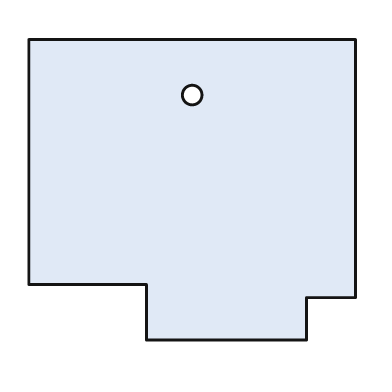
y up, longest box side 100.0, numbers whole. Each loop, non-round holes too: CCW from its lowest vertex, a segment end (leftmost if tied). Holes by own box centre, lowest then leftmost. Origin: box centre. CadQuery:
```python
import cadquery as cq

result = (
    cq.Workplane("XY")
    .moveTo(-14.0, -46.0)
    .lineTo(35.0, -46.0)
    .lineTo(35.0, -33.0)
    .lineTo(50.0, -33.0)
    .lineTo(50.0, 46.0)
    .lineTo(-50.0, 46.0)
    .lineTo(-50.0, -29.0)
    .lineTo(-14.0, -29.0)
    .close()
    .moveTo(0.0, 29.0)
    .circle(3.0)
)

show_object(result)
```